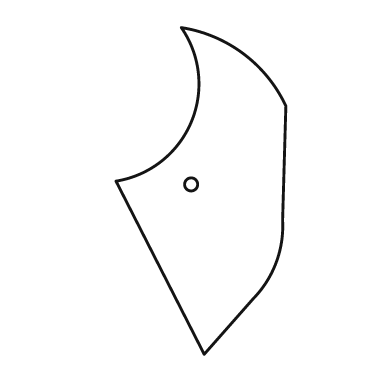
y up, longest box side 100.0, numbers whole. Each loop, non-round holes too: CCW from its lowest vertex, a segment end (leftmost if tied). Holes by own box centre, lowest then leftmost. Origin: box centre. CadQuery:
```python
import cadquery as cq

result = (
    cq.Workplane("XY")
    .moveTo(1.0, -50.0)
    .lineTo(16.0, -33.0)
    .threePointArc((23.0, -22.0), (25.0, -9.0))
    .lineTo(26.0, 26.0)
    .threePointArc((13.0, 42.0), (-6.0, 50.0))
    .threePointArc((-3.0, 21.0), (-26.0, 3.0))
    .close()
    .moveTo(-3.0, 2.0)
    .circle(2.0)
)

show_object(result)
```